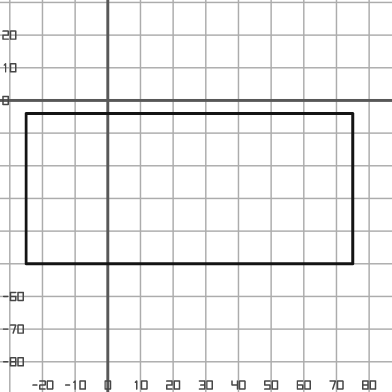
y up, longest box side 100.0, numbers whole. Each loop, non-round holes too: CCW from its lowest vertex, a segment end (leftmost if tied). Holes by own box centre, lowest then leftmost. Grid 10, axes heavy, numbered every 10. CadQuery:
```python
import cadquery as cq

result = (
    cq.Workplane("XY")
    .moveTo(-25.0, -50.0)
    .lineTo(75.0, -50.0)
    .lineTo(75.0, -4.0)
    .lineTo(-25.0, -4.0)
    .close()
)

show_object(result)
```